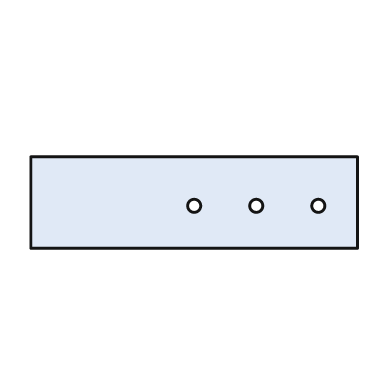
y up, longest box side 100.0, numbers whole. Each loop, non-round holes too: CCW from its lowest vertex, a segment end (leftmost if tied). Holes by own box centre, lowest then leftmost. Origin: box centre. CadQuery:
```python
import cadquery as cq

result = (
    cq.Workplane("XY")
    .moveTo(-50.0, -14.0)
    .lineTo(50.0, -14.0)
    .lineTo(50.0, 14.0)
    .lineTo(-50.0, 14.0)
    .close()
    .moveTo(0.0, -1.0)
    .circle(2.0)
    .moveTo(19.0, -1.0)
    .circle(2.0)
    .moveTo(38.0, -1.0)
    .circle(2.0)
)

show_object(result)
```